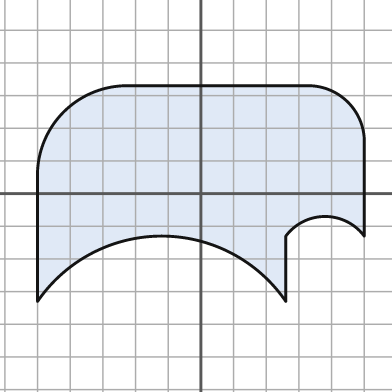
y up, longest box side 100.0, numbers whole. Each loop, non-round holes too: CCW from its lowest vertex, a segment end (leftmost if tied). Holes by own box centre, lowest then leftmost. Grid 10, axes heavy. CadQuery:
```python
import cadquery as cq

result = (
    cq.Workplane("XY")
    .moveTo(-50.0, -33.0)
    .threePointArc((-12.0, -13.0), (26.0, -33.0))
    .lineTo(26.0, -13.0)
    .threePointArc((38.0, -7.0), (50.0, -13.0))
    .lineTo(50.0, 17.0)
    .threePointArc((45.0, 28.0), (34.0, 33.0))
    .lineTo(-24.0, 33.0)
    .threePointArc((-42.0, 25.0), (-50.0, 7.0))
    .close()
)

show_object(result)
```